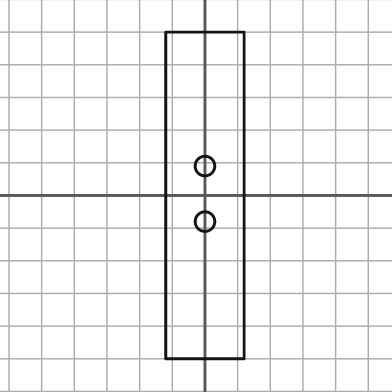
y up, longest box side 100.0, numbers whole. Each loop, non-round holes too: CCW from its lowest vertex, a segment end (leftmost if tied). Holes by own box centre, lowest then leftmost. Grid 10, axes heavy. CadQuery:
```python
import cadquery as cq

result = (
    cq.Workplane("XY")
    .moveTo(-12.0, -50.0)
    .lineTo(12.0, -50.0)
    .lineTo(12.0, 50.0)
    .lineTo(-12.0, 50.0)
    .close()
    .moveTo(0.0, -8.0)
    .circle(3.0)
    .moveTo(0.0, 9.0)
    .circle(3.0)
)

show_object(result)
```